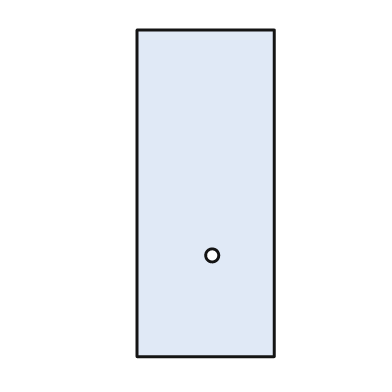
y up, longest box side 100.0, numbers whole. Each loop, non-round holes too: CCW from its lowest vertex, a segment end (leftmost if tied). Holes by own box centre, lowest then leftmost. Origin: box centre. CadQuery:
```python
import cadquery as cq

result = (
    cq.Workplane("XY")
    .moveTo(-21.0, -50.0)
    .lineTo(21.0, -50.0)
    .lineTo(21.0, 50.0)
    .lineTo(-21.0, 50.0)
    .close()
    .moveTo(2.0, -19.0)
    .circle(2.0)
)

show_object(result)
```